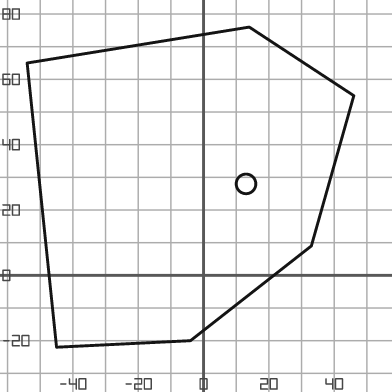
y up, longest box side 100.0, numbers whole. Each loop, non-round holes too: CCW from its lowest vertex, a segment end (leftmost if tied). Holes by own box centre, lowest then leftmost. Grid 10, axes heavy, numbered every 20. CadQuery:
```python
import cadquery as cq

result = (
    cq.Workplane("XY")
    .moveTo(-45.0, -22.0)
    .lineTo(-4.0, -20.0)
    .lineTo(33.0, 9.0)
    .lineTo(46.0, 55.0)
    .lineTo(14.0, 76.0)
    .lineTo(-54.0, 65.0)
    .close()
    .moveTo(13.0, 28.0)
    .circle(3.0)
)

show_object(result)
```